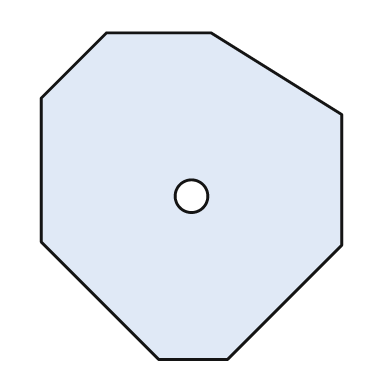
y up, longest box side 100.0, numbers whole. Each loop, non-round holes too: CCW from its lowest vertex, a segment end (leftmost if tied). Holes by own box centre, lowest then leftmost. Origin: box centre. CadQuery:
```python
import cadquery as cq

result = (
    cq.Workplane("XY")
    .moveTo(-10.0, -50.0)
    .lineTo(11.0, -50.0)
    .lineTo(46.0, -15.0)
    .lineTo(46.0, 25.0)
    .lineTo(6.0, 50.0)
    .lineTo(-26.0, 50.0)
    .lineTo(-46.0, 30.0)
    .lineTo(-46.0, -14.0)
    .close()
    .moveTo(0.0, 0.0)
    .circle(5.0)
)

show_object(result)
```